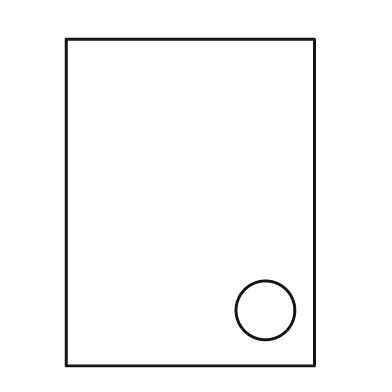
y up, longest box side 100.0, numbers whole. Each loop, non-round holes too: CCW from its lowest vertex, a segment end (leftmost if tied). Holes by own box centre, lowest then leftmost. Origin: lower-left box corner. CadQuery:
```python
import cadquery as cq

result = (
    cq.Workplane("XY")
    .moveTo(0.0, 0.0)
    .lineTo(76.0, 0.0)
    .lineTo(76.0, 100.0)
    .lineTo(0.0, 100.0)
    .close()
    .moveTo(61.0, 17.0)
    .circle(9.0)
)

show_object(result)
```